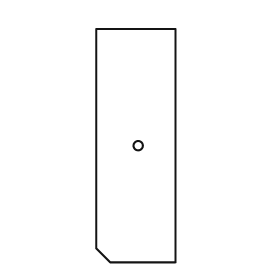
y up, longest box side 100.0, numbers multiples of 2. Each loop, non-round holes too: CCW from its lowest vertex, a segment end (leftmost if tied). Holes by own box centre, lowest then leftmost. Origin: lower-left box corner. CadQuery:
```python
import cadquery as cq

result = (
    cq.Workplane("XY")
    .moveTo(6.0, 0.0)
    .lineTo(34.0, 0.0)
    .lineTo(34.0, 100.0)
    .lineTo(0.0, 100.0)
    .lineTo(0.0, 6.0)
    .close()
    .moveTo(18.0, 50.0)
    .circle(2.0)
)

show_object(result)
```